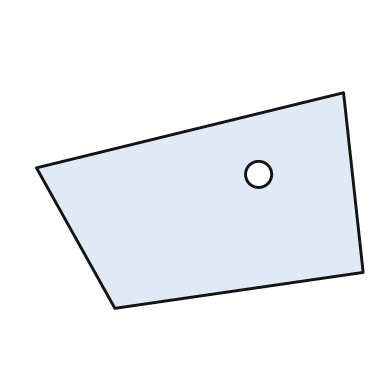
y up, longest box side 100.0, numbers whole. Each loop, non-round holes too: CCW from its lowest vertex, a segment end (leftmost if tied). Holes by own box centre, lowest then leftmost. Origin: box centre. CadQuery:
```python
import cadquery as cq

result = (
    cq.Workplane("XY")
    .moveTo(-26.0, -33.0)
    .lineTo(50.0, -22.0)
    .lineTo(44.0, 33.0)
    .lineTo(-50.0, 10.0)
    .close()
    .moveTo(18.0, 8.0)
    .circle(4.0)
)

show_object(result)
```